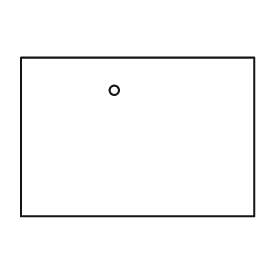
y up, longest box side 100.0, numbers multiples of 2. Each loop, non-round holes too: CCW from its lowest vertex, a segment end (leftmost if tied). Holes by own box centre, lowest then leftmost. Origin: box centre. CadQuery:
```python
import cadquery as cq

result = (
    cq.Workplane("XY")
    .moveTo(-50.0, -34.0)
    .lineTo(50.0, -34.0)
    .lineTo(50.0, 34.0)
    .lineTo(-50.0, 34.0)
    .close()
    .moveTo(-10.0, 20.0)
    .circle(2.0)
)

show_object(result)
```